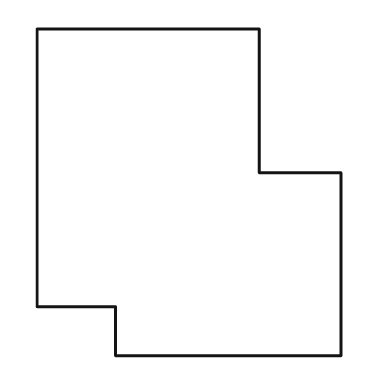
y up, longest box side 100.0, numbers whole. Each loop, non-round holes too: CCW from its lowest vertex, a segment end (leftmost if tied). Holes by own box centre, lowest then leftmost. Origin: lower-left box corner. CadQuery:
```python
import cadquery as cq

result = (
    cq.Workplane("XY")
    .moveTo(24.0, 0.0)
    .lineTo(93.0, 0.0)
    .lineTo(93.0, 56.0)
    .lineTo(68.0, 56.0)
    .lineTo(68.0, 100.0)
    .lineTo(0.0, 100.0)
    .lineTo(0.0, 15.0)
    .lineTo(24.0, 15.0)
    .close()
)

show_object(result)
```